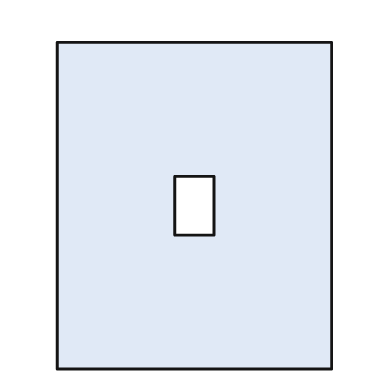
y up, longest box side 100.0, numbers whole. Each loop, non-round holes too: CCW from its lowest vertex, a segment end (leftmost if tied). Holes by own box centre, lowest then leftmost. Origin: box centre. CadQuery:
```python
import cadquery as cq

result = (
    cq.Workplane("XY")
    .moveTo(-42.0, -50.0)
    .lineTo(42.0, -50.0)
    .lineTo(42.0, 50.0)
    .lineTo(-42.0, 50.0)
    .close()
    .moveTo(-6.0, -9.0)
    .lineTo(6.0, -9.0)
    .lineTo(6.0, 9.0)
    .lineTo(-6.0, 9.0)
    .close()
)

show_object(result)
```